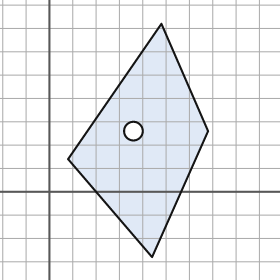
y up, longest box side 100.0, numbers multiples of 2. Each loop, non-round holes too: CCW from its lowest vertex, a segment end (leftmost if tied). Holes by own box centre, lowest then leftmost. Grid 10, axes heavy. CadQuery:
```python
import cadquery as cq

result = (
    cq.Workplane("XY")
    .moveTo(44.0, -28.0)
    .lineTo(68.0, 26.0)
    .lineTo(48.0, 72.0)
    .lineTo(8.0, 14.0)
    .close()
    .moveTo(36.0, 26.0)
    .circle(4.0)
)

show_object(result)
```